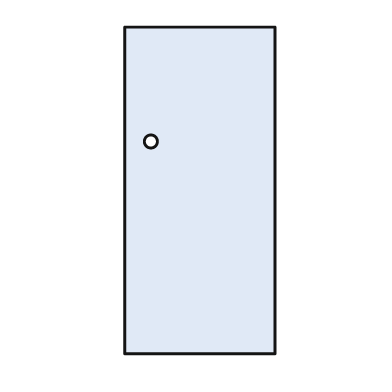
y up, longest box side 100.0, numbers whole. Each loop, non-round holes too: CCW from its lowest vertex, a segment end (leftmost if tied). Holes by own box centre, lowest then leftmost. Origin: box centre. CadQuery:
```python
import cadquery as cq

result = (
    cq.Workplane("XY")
    .moveTo(-23.0, -50.0)
    .lineTo(23.0, -50.0)
    .lineTo(23.0, 50.0)
    .lineTo(-23.0, 50.0)
    .close()
    .moveTo(-15.0, 15.0)
    .circle(2.0)
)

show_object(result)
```